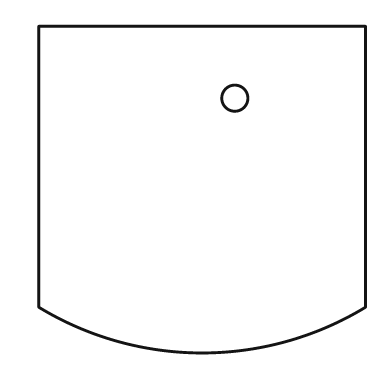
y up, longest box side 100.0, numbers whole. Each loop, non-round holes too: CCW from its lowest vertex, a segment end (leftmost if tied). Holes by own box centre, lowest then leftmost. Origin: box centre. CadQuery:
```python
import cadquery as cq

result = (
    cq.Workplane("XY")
    .moveTo(-50.0, -36.0)
    .threePointArc((0.0, -50.0), (50.0, -36.0))
    .lineTo(50.0, 50.0)
    .lineTo(-50.0, 50.0)
    .close()
    .moveTo(10.0, 28.0)
    .circle(4.0)
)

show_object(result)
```